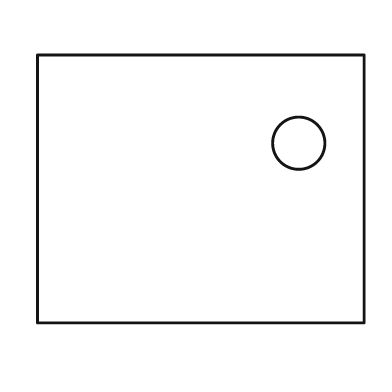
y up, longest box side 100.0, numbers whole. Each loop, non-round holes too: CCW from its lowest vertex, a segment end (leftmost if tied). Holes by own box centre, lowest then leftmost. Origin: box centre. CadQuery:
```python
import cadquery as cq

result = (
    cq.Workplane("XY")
    .moveTo(-50.0, -41.0)
    .lineTo(50.0, -41.0)
    .lineTo(50.0, 41.0)
    .lineTo(-50.0, 41.0)
    .close()
    .moveTo(30.0, 14.0)
    .circle(8.0)
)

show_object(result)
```